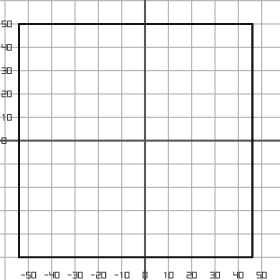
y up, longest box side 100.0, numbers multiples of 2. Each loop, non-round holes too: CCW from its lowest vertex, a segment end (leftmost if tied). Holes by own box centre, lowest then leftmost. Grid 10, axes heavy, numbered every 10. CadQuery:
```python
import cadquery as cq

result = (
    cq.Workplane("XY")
    .moveTo(-54.0, -50.0)
    .lineTo(46.0, -50.0)
    .lineTo(46.0, 50.0)
    .lineTo(-54.0, 50.0)
    .close()
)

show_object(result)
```